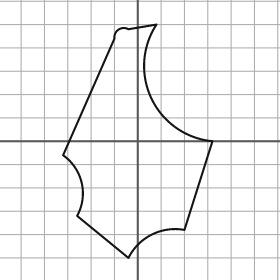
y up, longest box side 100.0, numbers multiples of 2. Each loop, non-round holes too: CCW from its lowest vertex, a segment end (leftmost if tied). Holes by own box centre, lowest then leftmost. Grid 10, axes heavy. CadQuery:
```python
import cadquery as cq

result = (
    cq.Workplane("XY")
    .moveTo(-4.0, -50.0)
    .threePointArc((6.0, -40.0), (20.0, -38.0))
    .lineTo(32.0, 0.0)
    .threePointArc((6.0, 18.0), (8.0, 50.0))
    .lineTo(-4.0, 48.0)
    .threePointArc((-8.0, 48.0), (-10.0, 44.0))
    .lineTo(-32.0, -6.0)
    .threePointArc((-24.0, -18.0), (-26.0, -32.0))
    .close()
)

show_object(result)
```